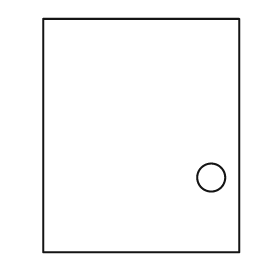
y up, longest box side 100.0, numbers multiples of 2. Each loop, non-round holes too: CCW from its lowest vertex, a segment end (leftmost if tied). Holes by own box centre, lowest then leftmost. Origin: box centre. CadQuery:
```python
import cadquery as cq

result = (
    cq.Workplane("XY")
    .moveTo(-42.0, -50.0)
    .lineTo(42.0, -50.0)
    .lineTo(42.0, 50.0)
    .lineTo(-42.0, 50.0)
    .close()
    .moveTo(30.0, -18.0)
    .circle(6.0)
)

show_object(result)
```